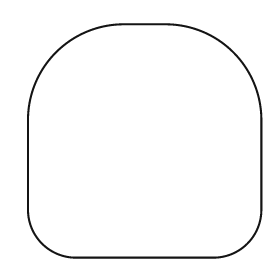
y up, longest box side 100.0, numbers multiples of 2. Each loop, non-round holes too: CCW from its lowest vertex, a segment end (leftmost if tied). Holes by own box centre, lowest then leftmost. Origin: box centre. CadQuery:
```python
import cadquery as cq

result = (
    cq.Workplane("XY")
    .moveTo(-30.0, -50.0)
    .lineTo(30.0, -50.0)
    .threePointArc((44.0, -44.0), (50.0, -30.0))
    .lineTo(50.0, 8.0)
    .threePointArc((38.0, 38.0), (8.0, 50.0))
    .lineTo(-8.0, 50.0)
    .threePointArc((-38.0, 38.0), (-50.0, 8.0))
    .lineTo(-50.0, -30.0)
    .threePointArc((-44.0, -44.0), (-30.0, -50.0))
    .close()
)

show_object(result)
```